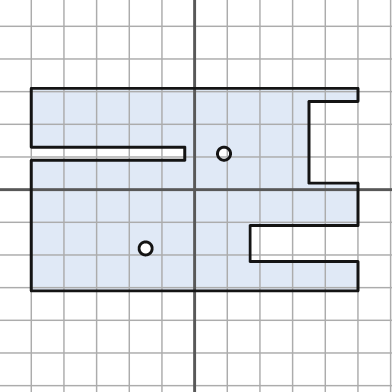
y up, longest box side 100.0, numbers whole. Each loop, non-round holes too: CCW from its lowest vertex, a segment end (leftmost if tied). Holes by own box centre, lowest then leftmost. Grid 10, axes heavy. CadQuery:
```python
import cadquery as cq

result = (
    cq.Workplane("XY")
    .moveTo(-50.0, -31.0)
    .lineTo(50.0, -31.0)
    .lineTo(50.0, -22.0)
    .lineTo(17.0, -22.0)
    .lineTo(17.0, -11.0)
    .lineTo(50.0, -11.0)
    .lineTo(50.0, 2.0)
    .lineTo(35.0, 2.0)
    .lineTo(35.0, 27.0)
    .lineTo(50.0, 27.0)
    .lineTo(50.0, 31.0)
    .lineTo(-50.0, 31.0)
    .lineTo(-50.0, 13.0)
    .lineTo(-3.0, 13.0)
    .lineTo(-3.0, 9.0)
    .lineTo(-50.0, 9.0)
    .close()
    .moveTo(-15.0, -18.0)
    .circle(2.0)
    .moveTo(9.0, 11.0)
    .circle(2.0)
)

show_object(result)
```